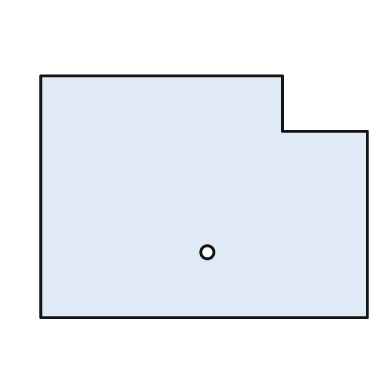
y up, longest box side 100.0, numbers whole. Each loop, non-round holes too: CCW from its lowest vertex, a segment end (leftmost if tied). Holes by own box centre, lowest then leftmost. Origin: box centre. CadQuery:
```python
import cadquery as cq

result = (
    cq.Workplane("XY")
    .moveTo(-50.0, -37.0)
    .lineTo(50.0, -37.0)
    .lineTo(50.0, 20.0)
    .lineTo(24.0, 20.0)
    .lineTo(24.0, 37.0)
    .lineTo(-50.0, 37.0)
    .close()
    .moveTo(1.0, -17.0)
    .circle(2.0)
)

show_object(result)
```